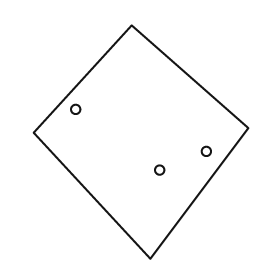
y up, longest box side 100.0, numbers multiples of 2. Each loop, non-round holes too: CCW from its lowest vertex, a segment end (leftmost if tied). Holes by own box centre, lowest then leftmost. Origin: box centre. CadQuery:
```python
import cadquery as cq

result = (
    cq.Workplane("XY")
    .moveTo(4.0, -50.0)
    .lineTo(46.0, 6.0)
    .lineTo(-4.0, 50.0)
    .lineTo(-46.0, 4.0)
    .close()
    .moveTo(8.0, -12.0)
    .circle(2.0)
    .moveTo(28.0, -4.0)
    .circle(2.0)
    .moveTo(-28.0, 14.0)
    .circle(2.0)
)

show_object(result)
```